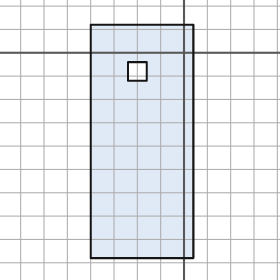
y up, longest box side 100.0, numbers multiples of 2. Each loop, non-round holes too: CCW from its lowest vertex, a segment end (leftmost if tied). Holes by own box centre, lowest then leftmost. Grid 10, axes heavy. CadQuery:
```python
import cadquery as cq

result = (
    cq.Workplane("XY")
    .moveTo(-40.0, -88.0)
    .lineTo(4.0, -88.0)
    .lineTo(4.0, 12.0)
    .lineTo(-40.0, 12.0)
    .close()
    .moveTo(-24.0, -12.0)
    .lineTo(-16.0, -12.0)
    .lineTo(-16.0, -4.0)
    .lineTo(-24.0, -4.0)
    .close()
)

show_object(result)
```